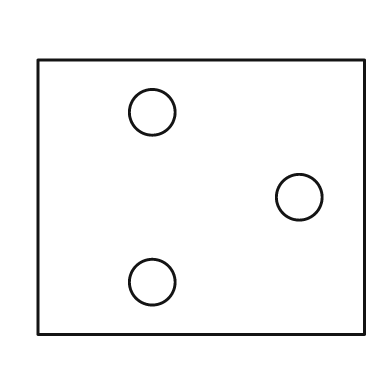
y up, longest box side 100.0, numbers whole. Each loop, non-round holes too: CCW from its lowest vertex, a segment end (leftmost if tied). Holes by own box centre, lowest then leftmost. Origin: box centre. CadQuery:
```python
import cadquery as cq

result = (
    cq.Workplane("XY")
    .moveTo(-50.0, -42.0)
    .lineTo(50.0, -42.0)
    .lineTo(50.0, 42.0)
    .lineTo(-50.0, 42.0)
    .close()
    .moveTo(-15.0, -26.0)
    .circle(7.0)
    .moveTo(30.0, 0.0)
    .circle(7.0)
    .moveTo(-15.0, 26.0)
    .circle(7.0)
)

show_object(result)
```